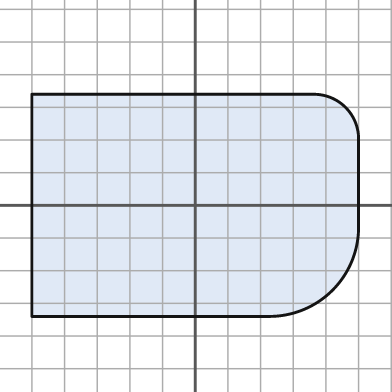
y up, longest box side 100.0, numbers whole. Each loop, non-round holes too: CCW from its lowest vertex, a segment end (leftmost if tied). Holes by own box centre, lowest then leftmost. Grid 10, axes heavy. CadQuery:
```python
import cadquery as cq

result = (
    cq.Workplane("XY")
    .moveTo(-50.0, -34.0)
    .lineTo(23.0, -34.0)
    .threePointArc((42.0, -26.0), (50.0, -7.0))
    .lineTo(50.0, 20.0)
    .threePointArc((46.0, 30.0), (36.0, 34.0))
    .lineTo(-50.0, 34.0)
    .close()
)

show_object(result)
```